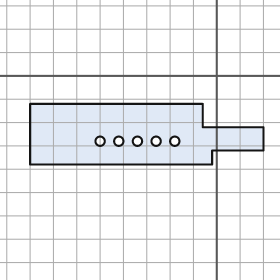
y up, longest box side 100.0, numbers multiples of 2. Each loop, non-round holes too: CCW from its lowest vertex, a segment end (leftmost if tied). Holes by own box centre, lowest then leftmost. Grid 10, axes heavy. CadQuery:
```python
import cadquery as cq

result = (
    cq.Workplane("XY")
    .moveTo(-80.0, -38.0)
    .lineTo(-2.0, -38.0)
    .lineTo(-2.0, -32.0)
    .lineTo(20.0, -32.0)
    .lineTo(20.0, -22.0)
    .lineTo(-6.0, -22.0)
    .lineTo(-6.0, -12.0)
    .lineTo(-80.0, -12.0)
    .close()
    .moveTo(-50.0, -28.0)
    .circle(2.0)
    .moveTo(-42.0, -28.0)
    .circle(2.0)
    .moveTo(-34.0, -28.0)
    .circle(2.0)
    .moveTo(-26.0, -28.0)
    .circle(2.0)
    .moveTo(-18.0, -28.0)
    .circle(2.0)
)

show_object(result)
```